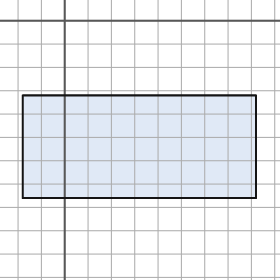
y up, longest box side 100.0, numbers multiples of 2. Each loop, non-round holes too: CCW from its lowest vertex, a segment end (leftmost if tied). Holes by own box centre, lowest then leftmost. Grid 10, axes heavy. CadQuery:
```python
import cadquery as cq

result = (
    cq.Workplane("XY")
    .moveTo(-18.0, -76.0)
    .lineTo(82.0, -76.0)
    .lineTo(82.0, -32.0)
    .lineTo(-18.0, -32.0)
    .close()
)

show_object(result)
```